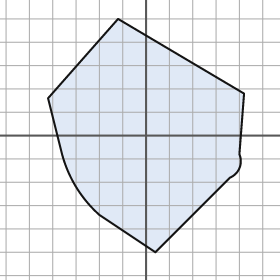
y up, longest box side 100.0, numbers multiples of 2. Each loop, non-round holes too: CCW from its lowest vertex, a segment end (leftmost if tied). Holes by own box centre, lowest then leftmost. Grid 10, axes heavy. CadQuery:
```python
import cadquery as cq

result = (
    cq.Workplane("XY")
    .moveTo(4.0, -50.0)
    .lineTo(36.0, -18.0)
    .threePointArc((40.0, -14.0), (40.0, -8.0))
    .lineTo(42.0, 18.0)
    .lineTo(-12.0, 50.0)
    .lineTo(-42.0, 16.0)
    .lineTo(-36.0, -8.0)
    .threePointArc((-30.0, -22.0), (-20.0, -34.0))
    .close()
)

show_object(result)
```